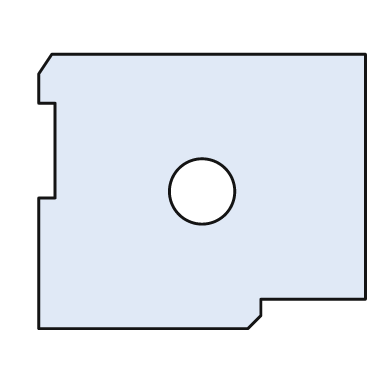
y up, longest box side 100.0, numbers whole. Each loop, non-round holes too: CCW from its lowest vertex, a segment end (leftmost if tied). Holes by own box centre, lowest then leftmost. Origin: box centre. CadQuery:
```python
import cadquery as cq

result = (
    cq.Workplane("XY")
    .moveTo(-50.0, -42.0)
    .lineTo(14.0, -42.0)
    .lineTo(18.0, -38.0)
    .lineTo(18.0, -33.0)
    .lineTo(50.0, -33.0)
    .lineTo(50.0, 42.0)
    .lineTo(-46.0, 42.0)
    .lineTo(-50.0, 36.0)
    .lineTo(-50.0, 27.0)
    .lineTo(-45.0, 27.0)
    .lineTo(-45.0, -2.0)
    .lineTo(-50.0, -2.0)
    .close()
    .moveTo(0.0, 0.0)
    .circle(10.0)
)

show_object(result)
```